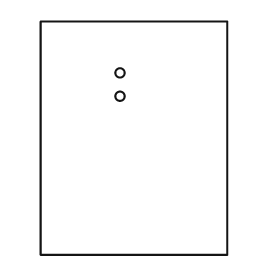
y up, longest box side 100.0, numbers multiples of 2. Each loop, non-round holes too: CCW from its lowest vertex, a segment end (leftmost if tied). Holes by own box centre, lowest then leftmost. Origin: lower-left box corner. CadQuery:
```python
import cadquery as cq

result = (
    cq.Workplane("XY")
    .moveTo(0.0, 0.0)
    .lineTo(80.0, 0.0)
    .lineTo(80.0, 100.0)
    .lineTo(0.0, 100.0)
    .close()
    .moveTo(34.0, 68.0)
    .circle(2.0)
    .moveTo(34.0, 78.0)
    .circle(2.0)
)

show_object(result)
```